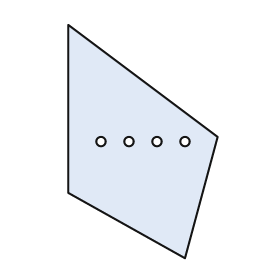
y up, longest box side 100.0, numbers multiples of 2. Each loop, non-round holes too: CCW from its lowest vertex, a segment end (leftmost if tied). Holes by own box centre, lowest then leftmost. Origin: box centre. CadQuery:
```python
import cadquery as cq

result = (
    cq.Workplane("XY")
    .moveTo(18.0, -50.0)
    .lineTo(32.0, 2.0)
    .lineTo(-32.0, 50.0)
    .lineTo(-32.0, -22.0)
    .close()
    .moveTo(-18.0, 0.0)
    .circle(2.0)
    .moveTo(-6.0, 0.0)
    .circle(2.0)
    .moveTo(6.0, 0.0)
    .circle(2.0)
    .moveTo(18.0, 0.0)
    .circle(2.0)
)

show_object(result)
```